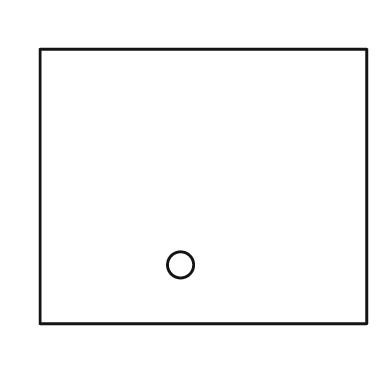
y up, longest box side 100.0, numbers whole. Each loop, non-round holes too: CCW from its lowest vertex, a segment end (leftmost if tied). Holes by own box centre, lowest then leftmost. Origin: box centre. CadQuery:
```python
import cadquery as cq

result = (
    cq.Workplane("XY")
    .moveTo(-50.0, -42.0)
    .lineTo(50.0, -42.0)
    .lineTo(50.0, 42.0)
    .lineTo(-50.0, 42.0)
    .close()
    .moveTo(-7.0, -24.0)
    .circle(4.0)
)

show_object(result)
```